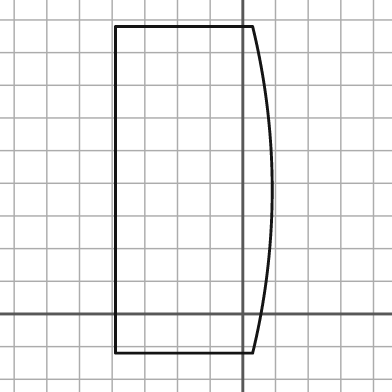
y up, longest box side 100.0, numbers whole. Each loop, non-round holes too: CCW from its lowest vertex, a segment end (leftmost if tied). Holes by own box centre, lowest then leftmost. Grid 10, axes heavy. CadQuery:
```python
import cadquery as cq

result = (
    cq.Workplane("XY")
    .moveTo(-39.0, -12.0)
    .lineTo(3.0, -12.0)
    .threePointArc((9.0, 38.0), (3.0, 88.0))
    .lineTo(-39.0, 88.0)
    .close()
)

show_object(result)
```